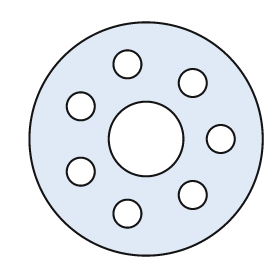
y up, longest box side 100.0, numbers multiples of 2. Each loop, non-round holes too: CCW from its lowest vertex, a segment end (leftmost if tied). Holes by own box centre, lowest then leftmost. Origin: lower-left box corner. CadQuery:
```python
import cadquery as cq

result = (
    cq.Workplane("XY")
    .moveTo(50.0, 50.0)
    .circle(50.0)
    .moveTo(42.0, 18.0)
    .circle(6.0)
    .moveTo(70.0, 26.0)
    .circle(6.0)
    .moveTo(22.0, 36.0)
    .circle(6.0)
    .moveTo(50.0, 50.0)
    .circle(16.0)
    .moveTo(82.0, 50.0)
    .circle(6.0)
    .moveTo(22.0, 64.0)
    .circle(6.0)
    .moveTo(70.0, 74.0)
    .circle(6.0)
    .moveTo(42.0, 82.0)
    .circle(6.0)
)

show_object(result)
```